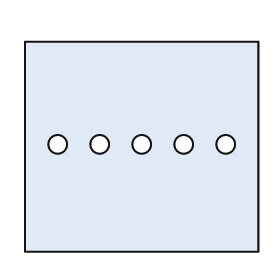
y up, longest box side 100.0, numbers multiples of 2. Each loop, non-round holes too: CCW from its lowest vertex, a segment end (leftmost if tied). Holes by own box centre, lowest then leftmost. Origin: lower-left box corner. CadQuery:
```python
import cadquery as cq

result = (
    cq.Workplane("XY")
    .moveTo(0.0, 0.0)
    .lineTo(100.0, 0.0)
    .lineTo(100.0, 90.0)
    .lineTo(0.0, 90.0)
    .close()
    .moveTo(14.0, 46.0)
    .circle(4.0)
    .moveTo(32.0, 46.0)
    .circle(4.0)
    .moveTo(50.0, 46.0)
    .circle(4.0)
    .moveTo(68.0, 46.0)
    .circle(4.0)
    .moveTo(86.0, 46.0)
    .circle(4.0)
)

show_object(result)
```